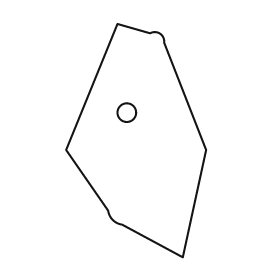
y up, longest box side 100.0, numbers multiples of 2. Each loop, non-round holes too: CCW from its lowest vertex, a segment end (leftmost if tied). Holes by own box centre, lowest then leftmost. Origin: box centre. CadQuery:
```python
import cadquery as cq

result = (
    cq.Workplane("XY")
    .moveTo(20.0, -50.0)
    .lineTo(30.0, -4.0)
    .lineTo(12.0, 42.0)
    .threePointArc((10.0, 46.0), (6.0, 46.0))
    .lineTo(-8.0, 50.0)
    .lineTo(-30.0, -4.0)
    .lineTo(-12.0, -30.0)
    .threePointArc((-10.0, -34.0), (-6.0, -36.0))
    .close()
    .moveTo(-4.0, 12.0)
    .circle(4.0)
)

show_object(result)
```